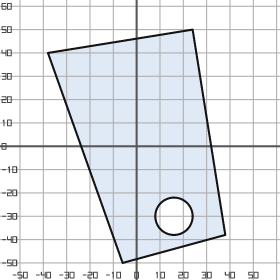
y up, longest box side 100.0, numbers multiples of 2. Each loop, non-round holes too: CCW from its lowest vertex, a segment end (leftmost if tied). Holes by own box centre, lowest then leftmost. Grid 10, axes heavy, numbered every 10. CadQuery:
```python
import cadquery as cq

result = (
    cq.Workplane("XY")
    .moveTo(-6.0, -50.0)
    .lineTo(38.0, -38.0)
    .lineTo(24.0, 50.0)
    .lineTo(-38.0, 40.0)
    .close()
    .moveTo(16.0, -30.0)
    .circle(8.0)
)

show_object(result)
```